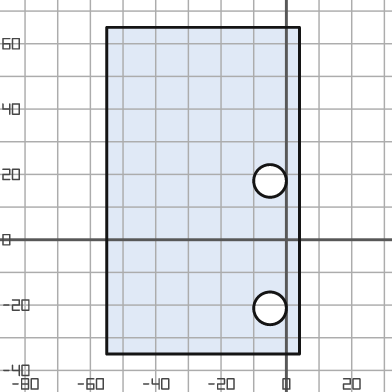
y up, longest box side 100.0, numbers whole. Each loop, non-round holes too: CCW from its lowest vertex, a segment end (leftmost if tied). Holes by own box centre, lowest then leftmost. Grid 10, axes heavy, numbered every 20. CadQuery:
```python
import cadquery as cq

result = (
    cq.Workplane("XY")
    .moveTo(-55.0, -35.0)
    .lineTo(4.0, -35.0)
    .lineTo(4.0, 65.0)
    .lineTo(-55.0, 65.0)
    .close()
    .moveTo(-5.0, -21.0)
    .circle(5.0)
    .moveTo(-5.0, 18.0)
    .circle(5.0)
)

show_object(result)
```